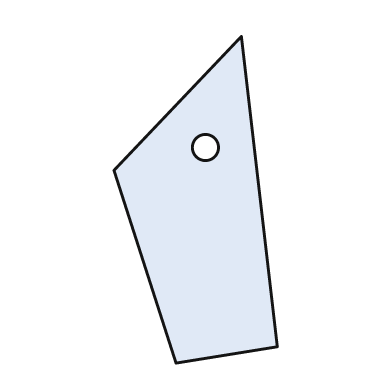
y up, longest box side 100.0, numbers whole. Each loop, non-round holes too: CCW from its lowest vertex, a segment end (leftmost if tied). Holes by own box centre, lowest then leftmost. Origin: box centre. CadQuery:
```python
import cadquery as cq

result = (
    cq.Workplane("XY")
    .moveTo(-6.0, -50.0)
    .lineTo(25.0, -45.0)
    .lineTo(14.0, 50.0)
    .lineTo(-25.0, 9.0)
    .close()
    .moveTo(3.0, 16.0)
    .circle(4.0)
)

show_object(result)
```